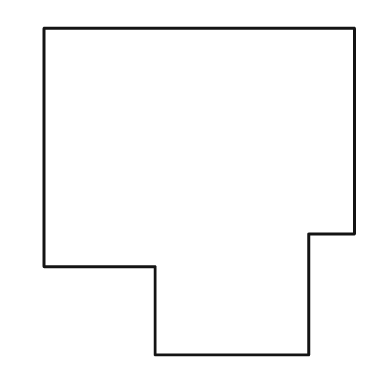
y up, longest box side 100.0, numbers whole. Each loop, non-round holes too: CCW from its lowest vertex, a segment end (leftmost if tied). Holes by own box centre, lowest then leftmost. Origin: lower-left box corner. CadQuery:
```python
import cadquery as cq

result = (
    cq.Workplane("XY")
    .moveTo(34.0, 0.0)
    .lineTo(81.0, 0.0)
    .lineTo(81.0, 37.0)
    .lineTo(95.0, 37.0)
    .lineTo(95.0, 100.0)
    .lineTo(0.0, 100.0)
    .lineTo(0.0, 27.0)
    .lineTo(34.0, 27.0)
    .close()
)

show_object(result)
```